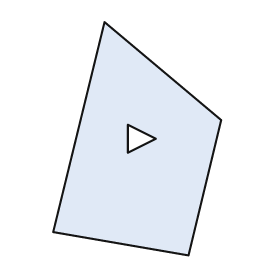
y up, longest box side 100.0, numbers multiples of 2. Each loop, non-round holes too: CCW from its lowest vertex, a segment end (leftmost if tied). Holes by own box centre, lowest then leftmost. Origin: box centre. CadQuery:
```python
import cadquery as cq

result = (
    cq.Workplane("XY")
    .moveTo(22.0, -50.0)
    .lineTo(36.0, 8.0)
    .lineTo(-14.0, 50.0)
    .lineTo(-36.0, -40.0)
    .close()
    .moveTo(-4.0, -6.0)
    .lineTo(8.0, 0.0)
    .lineTo(-4.0, 6.0)
    .close()
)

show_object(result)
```